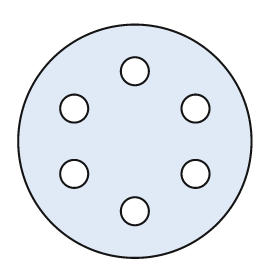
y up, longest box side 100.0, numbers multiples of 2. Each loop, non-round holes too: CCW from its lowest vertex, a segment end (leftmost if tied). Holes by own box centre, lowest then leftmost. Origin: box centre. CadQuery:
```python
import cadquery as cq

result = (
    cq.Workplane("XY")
    .moveTo(0.0, 0.0)
    .circle(50.0)
    .moveTo(0.0, -30.0)
    .circle(6.0)
    .moveTo(-26.0, -14.0)
    .circle(6.0)
    .moveTo(26.0, -14.0)
    .circle(6.0)
    .moveTo(-26.0, 14.0)
    .circle(6.0)
    .moveTo(26.0, 14.0)
    .circle(6.0)
    .moveTo(0.0, 30.0)
    .circle(6.0)
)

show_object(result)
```